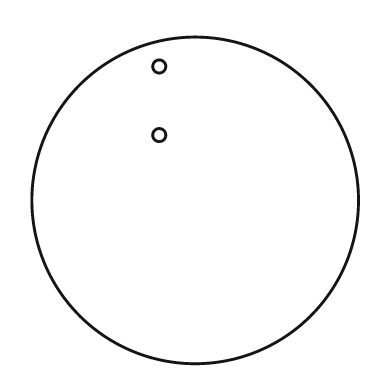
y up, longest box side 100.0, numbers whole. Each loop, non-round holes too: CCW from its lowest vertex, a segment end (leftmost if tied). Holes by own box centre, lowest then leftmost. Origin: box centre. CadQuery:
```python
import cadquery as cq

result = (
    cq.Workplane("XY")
    .moveTo(0.0, 0.0)
    .circle(50.0)
    .moveTo(-11.0, 20.0)
    .circle(2.0)
    .moveTo(-11.0, 41.0)
    .circle(2.0)
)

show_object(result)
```